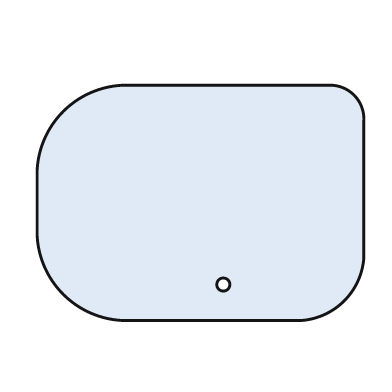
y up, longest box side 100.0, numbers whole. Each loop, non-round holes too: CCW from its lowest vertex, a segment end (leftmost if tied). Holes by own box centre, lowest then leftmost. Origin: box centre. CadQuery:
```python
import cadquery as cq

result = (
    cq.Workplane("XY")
    .moveTo(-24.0, -36.0)
    .lineTo(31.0, -36.0)
    .threePointArc((44.0, -30.0), (50.0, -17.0))
    .lineTo(50.0, 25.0)
    .threePointArc((47.0, 33.0), (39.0, 36.0))
    .lineTo(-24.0, 36.0)
    .threePointArc((-42.0, 28.0), (-50.0, 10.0))
    .lineTo(-50.0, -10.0)
    .threePointArc((-42.0, -28.0), (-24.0, -36.0))
    .close()
    .moveTo(7.0, -25.0)
    .circle(2.0)
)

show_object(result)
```